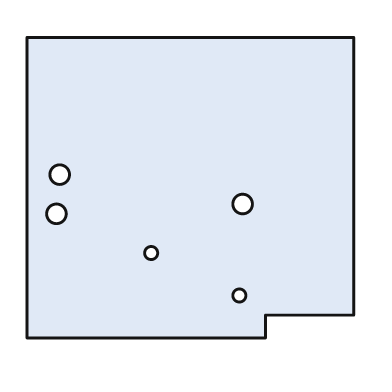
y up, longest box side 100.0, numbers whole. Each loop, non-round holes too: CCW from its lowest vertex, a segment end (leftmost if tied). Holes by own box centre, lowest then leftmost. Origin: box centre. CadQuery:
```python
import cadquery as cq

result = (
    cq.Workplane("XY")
    .moveTo(-50.0, -46.0)
    .lineTo(23.0, -46.0)
    .lineTo(23.0, -39.0)
    .lineTo(50.0, -39.0)
    .lineTo(50.0, 46.0)
    .lineTo(-50.0, 46.0)
    .close()
    .moveTo(15.0, -33.0)
    .circle(2.0)
    .moveTo(-12.0, -20.0)
    .circle(2.0)
    .moveTo(-41.0, -8.0)
    .circle(3.0)
    .moveTo(16.0, -5.0)
    .circle(3.0)
    .moveTo(-40.0, 4.0)
    .circle(3.0)
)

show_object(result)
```